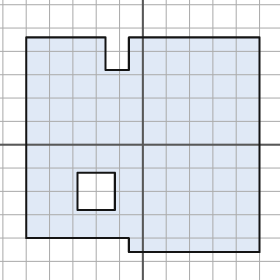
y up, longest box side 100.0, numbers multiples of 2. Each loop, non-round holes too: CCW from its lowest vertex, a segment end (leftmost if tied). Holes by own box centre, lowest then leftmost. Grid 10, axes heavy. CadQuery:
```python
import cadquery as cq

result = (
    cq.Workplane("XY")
    .moveTo(-6.0, -46.0)
    .lineTo(50.0, -46.0)
    .lineTo(50.0, 46.0)
    .lineTo(-6.0, 46.0)
    .lineTo(-6.0, 32.0)
    .lineTo(-16.0, 32.0)
    .lineTo(-16.0, 46.0)
    .lineTo(-50.0, 46.0)
    .lineTo(-50.0, -40.0)
    .lineTo(-6.0, -40.0)
    .close()
    .moveTo(-28.0, -28.0)
    .lineTo(-12.0, -28.0)
    .lineTo(-12.0, -12.0)
    .lineTo(-28.0, -12.0)
    .close()
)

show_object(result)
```